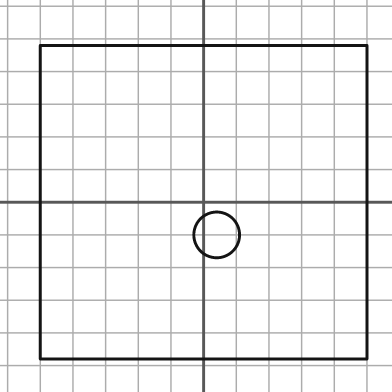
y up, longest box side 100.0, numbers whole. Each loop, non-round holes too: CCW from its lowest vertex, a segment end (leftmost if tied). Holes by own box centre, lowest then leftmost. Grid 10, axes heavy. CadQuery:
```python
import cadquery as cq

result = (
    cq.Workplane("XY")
    .moveTo(-50.0, -48.0)
    .lineTo(50.0, -48.0)
    .lineTo(50.0, 48.0)
    .lineTo(-50.0, 48.0)
    .close()
    .moveTo(4.0, -10.0)
    .circle(7.0)
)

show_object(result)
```